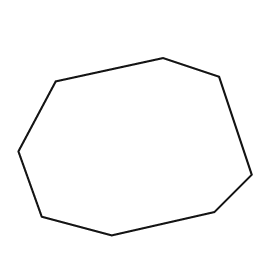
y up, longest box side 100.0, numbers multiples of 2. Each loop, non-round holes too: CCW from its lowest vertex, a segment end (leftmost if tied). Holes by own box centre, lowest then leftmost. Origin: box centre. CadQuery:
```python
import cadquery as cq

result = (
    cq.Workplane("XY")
    .moveTo(-10.0, -38.0)
    .lineTo(34.0, -28.0)
    .lineTo(50.0, -12.0)
    .lineTo(36.0, 30.0)
    .lineTo(12.0, 38.0)
    .lineTo(-34.0, 28.0)
    .lineTo(-50.0, -2.0)
    .lineTo(-40.0, -30.0)
    .close()
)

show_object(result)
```